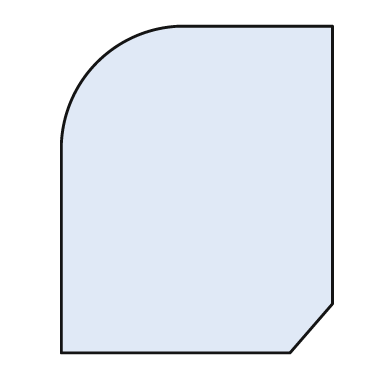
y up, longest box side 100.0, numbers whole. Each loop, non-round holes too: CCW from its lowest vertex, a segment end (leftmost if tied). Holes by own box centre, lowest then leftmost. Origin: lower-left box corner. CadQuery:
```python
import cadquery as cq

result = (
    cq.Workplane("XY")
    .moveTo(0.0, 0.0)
    .lineTo(70.0, 0.0)
    .lineTo(83.0, 15.0)
    .lineTo(83.0, 100.0)
    .lineTo(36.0, 100.0)
    .threePointArc((11.0, 89.0), (0.0, 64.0))
    .close()
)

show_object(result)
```